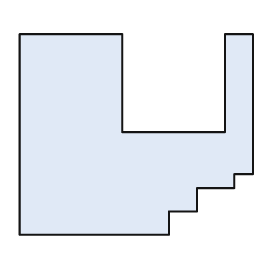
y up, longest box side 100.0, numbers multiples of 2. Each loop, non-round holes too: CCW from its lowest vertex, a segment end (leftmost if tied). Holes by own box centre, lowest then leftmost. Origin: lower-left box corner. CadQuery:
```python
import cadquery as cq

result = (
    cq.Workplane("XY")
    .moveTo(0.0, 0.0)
    .lineTo(64.0, 0.0)
    .lineTo(64.0, 10.0)
    .lineTo(76.0, 10.0)
    .lineTo(76.0, 20.0)
    .lineTo(92.0, 20.0)
    .lineTo(92.0, 26.0)
    .lineTo(100.0, 26.0)
    .lineTo(100.0, 86.0)
    .lineTo(88.0, 86.0)
    .lineTo(88.0, 44.0)
    .lineTo(44.0, 44.0)
    .lineTo(44.0, 86.0)
    .lineTo(0.0, 86.0)
    .close()
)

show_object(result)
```